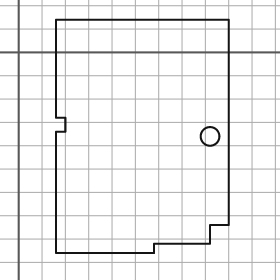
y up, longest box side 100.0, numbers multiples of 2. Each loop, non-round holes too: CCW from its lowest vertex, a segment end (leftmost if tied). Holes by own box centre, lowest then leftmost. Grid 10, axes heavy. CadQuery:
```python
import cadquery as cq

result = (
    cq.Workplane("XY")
    .moveTo(16.0, -86.0)
    .lineTo(58.0, -86.0)
    .lineTo(58.0, -82.0)
    .lineTo(82.0, -82.0)
    .lineTo(82.0, -74.0)
    .lineTo(90.0, -74.0)
    .lineTo(90.0, 14.0)
    .lineTo(16.0, 14.0)
    .lineTo(16.0, -28.0)
    .lineTo(20.0, -28.0)
    .lineTo(20.0, -34.0)
    .lineTo(16.0, -34.0)
    .close()
    .moveTo(82.0, -36.0)
    .circle(4.0)
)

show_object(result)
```